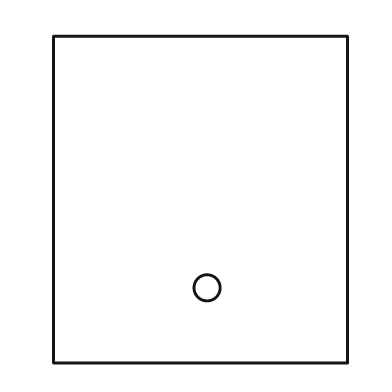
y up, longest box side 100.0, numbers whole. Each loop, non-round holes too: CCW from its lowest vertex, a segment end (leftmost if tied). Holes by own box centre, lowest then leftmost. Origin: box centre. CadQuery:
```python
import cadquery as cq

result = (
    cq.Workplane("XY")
    .moveTo(-45.0, -50.0)
    .lineTo(45.0, -50.0)
    .lineTo(45.0, 50.0)
    .lineTo(-45.0, 50.0)
    .close()
    .moveTo(2.0, -27.0)
    .circle(4.0)
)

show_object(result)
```